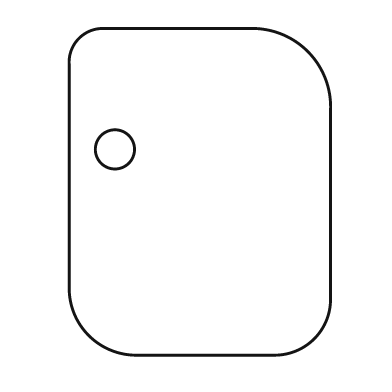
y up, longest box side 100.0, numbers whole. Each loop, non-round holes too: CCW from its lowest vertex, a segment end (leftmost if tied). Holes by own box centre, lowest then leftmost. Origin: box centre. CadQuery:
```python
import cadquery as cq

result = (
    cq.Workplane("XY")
    .moveTo(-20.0, -50.0)
    .lineTo(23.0, -50.0)
    .threePointArc((35.0, -45.0), (40.0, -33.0))
    .lineTo(40.0, 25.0)
    .threePointArc((33.0, 43.0), (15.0, 50.0))
    .lineTo(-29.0, 50.0)
    .threePointArc((-37.0, 47.0), (-40.0, 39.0))
    .lineTo(-40.0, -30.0)
    .threePointArc((-34.0, -44.0), (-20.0, -50.0))
    .close()
    .moveTo(-26.0, 13.0)
    .circle(6.0)
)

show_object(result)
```